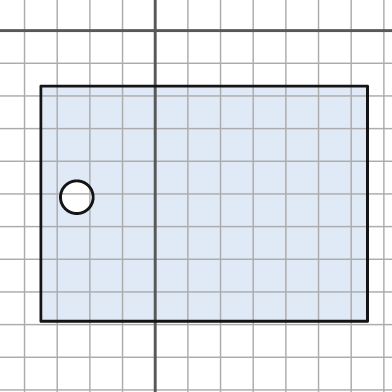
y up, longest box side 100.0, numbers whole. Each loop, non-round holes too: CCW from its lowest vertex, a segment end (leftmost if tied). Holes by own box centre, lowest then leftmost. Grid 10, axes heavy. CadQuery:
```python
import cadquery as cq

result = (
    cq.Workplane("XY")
    .moveTo(-35.0, -89.0)
    .lineTo(65.0, -89.0)
    .lineTo(65.0, -17.0)
    .lineTo(-35.0, -17.0)
    .close()
    .moveTo(-24.0, -51.0)
    .circle(5.0)
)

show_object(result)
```